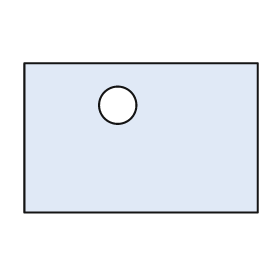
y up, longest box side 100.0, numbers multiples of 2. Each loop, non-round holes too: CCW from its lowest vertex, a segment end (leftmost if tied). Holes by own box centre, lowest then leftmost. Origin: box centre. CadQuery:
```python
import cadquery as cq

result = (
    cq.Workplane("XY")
    .moveTo(-50.0, -32.0)
    .lineTo(50.0, -32.0)
    .lineTo(50.0, 32.0)
    .lineTo(-50.0, 32.0)
    .close()
    .moveTo(-10.0, 14.0)
    .circle(8.0)
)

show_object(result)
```